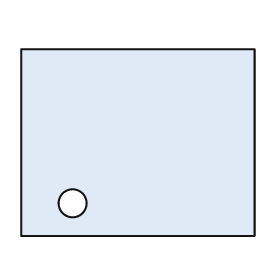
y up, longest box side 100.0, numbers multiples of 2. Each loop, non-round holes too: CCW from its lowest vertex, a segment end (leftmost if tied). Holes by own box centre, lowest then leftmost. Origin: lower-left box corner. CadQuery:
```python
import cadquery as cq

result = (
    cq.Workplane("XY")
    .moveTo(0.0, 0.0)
    .lineTo(100.0, 0.0)
    .lineTo(100.0, 80.0)
    .lineTo(0.0, 80.0)
    .close()
    .moveTo(22.0, 14.0)
    .circle(6.0)
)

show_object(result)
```